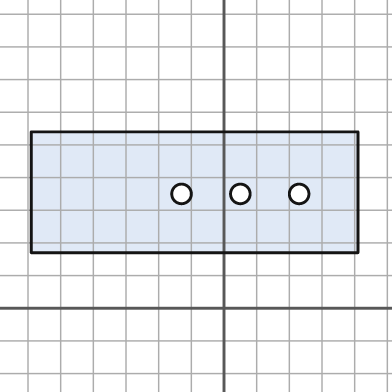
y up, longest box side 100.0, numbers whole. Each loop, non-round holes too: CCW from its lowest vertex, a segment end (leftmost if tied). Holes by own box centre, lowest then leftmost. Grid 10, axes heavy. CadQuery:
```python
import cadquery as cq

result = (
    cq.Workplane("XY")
    .moveTo(-59.0, 17.0)
    .lineTo(41.0, 17.0)
    .lineTo(41.0, 54.0)
    .lineTo(-59.0, 54.0)
    .close()
    .moveTo(-13.0, 35.0)
    .circle(3.0)
    .moveTo(5.0, 35.0)
    .circle(3.0)
    .moveTo(23.0, 35.0)
    .circle(3.0)
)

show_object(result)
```